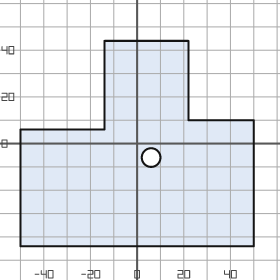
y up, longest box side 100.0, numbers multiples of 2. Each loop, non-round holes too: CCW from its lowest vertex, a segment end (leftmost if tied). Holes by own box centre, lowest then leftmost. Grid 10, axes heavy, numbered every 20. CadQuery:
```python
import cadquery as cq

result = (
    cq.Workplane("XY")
    .moveTo(-50.0, -44.0)
    .lineTo(50.0, -44.0)
    .lineTo(50.0, 10.0)
    .lineTo(22.0, 10.0)
    .lineTo(22.0, 44.0)
    .lineTo(-14.0, 44.0)
    .lineTo(-14.0, 6.0)
    .lineTo(-50.0, 6.0)
    .close()
    .moveTo(6.0, -6.0)
    .circle(4.0)
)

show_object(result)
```